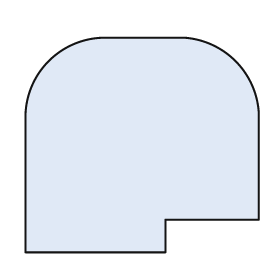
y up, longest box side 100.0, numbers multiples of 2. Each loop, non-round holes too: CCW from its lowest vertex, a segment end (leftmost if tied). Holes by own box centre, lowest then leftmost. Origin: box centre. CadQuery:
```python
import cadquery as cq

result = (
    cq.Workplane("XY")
    .moveTo(-50.0, -46.0)
    .lineTo(10.0, -46.0)
    .lineTo(10.0, -32.0)
    .lineTo(50.0, -32.0)
    .lineTo(50.0, 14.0)
    .threePointArc((40.0, 36.0), (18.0, 46.0))
    .lineTo(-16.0, 46.0)
    .threePointArc((-40.0, 36.0), (-50.0, 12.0))
    .close()
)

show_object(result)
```